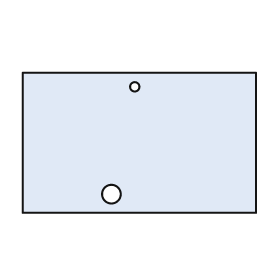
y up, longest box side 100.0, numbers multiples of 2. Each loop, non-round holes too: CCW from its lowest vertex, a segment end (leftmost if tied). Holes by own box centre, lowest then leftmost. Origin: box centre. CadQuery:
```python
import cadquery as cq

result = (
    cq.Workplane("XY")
    .moveTo(-50.0, -30.0)
    .lineTo(50.0, -30.0)
    .lineTo(50.0, 30.0)
    .lineTo(-50.0, 30.0)
    .close()
    .moveTo(-12.0, -22.0)
    .circle(4.0)
    .moveTo(-2.0, 24.0)
    .circle(2.0)
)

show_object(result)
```